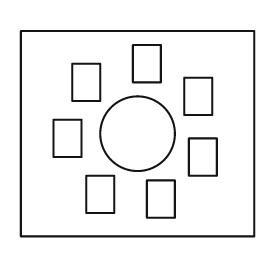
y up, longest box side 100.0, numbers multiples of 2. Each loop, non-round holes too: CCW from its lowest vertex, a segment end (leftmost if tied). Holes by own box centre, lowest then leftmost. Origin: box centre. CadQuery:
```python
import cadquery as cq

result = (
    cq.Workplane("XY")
    .moveTo(-50.0, -44.0)
    .lineTo(50.0, -44.0)
    .lineTo(50.0, 44.0)
    .lineTo(-50.0, 44.0)
    .close()
    .moveTo(4.0, -36.0)
    .lineTo(16.0, -36.0)
    .lineTo(16.0, -20.0)
    .lineTo(4.0, -20.0)
    .close()
    .moveTo(-22.0, -34.0)
    .lineTo(-10.0, -34.0)
    .lineTo(-10.0, -18.0)
    .lineTo(-22.0, -18.0)
    .close()
    .moveTo(22.0, -18.0)
    .lineTo(34.0, -18.0)
    .lineTo(34.0, -2.0)
    .lineTo(22.0, -2.0)
    .close()
    .moveTo(-36.0, -10.0)
    .lineTo(-24.0, -10.0)
    .lineTo(-24.0, 6.0)
    .lineTo(-36.0, 6.0)
    .close()
    .moveTo(0.0, 0.0)
    .circle(16.0)
    .moveTo(20.0, 8.0)
    .lineTo(32.0, 8.0)
    .lineTo(32.0, 24.0)
    .lineTo(20.0, 24.0)
    .close()
    .moveTo(-28.0, 14.0)
    .lineTo(-16.0, 14.0)
    .lineTo(-16.0, 30.0)
    .lineTo(-28.0, 30.0)
    .close()
    .moveTo(-2.0, 22.0)
    .lineTo(10.0, 22.0)
    .lineTo(10.0, 38.0)
    .lineTo(-2.0, 38.0)
    .close()
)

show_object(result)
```